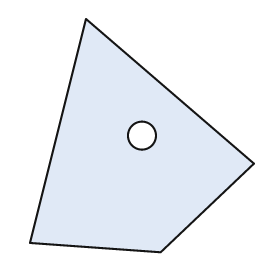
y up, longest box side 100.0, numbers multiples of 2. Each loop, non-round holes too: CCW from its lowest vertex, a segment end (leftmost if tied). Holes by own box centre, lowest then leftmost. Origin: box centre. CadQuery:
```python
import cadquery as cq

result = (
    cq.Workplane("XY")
    .moveTo(8.0, -50.0)
    .lineTo(48.0, -12.0)
    .lineTo(-24.0, 50.0)
    .lineTo(-48.0, -46.0)
    .close()
    .moveTo(0.0, 0.0)
    .circle(6.0)
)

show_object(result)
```